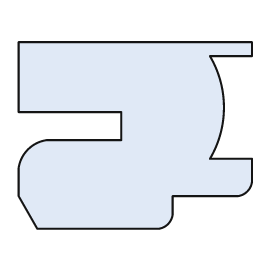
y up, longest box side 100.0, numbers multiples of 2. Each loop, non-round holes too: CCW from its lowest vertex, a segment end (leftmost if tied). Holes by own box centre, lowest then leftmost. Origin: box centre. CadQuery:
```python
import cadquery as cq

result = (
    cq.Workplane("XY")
    .moveTo(-42.0, -40.0)
    .lineTo(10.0, -40.0)
    .threePointArc((14.0, -38.0), (16.0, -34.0))
    .lineTo(16.0, -26.0)
    .lineTo(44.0, -26.0)
    .threePointArc((48.0, -24.0), (50.0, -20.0))
    .lineTo(50.0, -10.0)
    .lineTo(32.0, -10.0)
    .threePointArc((38.0, 12.0), (32.0, 34.0))
    .lineTo(50.0, 34.0)
    .lineTo(50.0, 40.0)
    .lineTo(-50.0, 40.0)
    .lineTo(-50.0, 10.0)
    .lineTo(-6.0, 10.0)
    .lineTo(-6.0, -2.0)
    .lineTo(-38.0, -2.0)
    .threePointArc((-46.0, -6.0), (-50.0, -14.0))
    .lineTo(-50.0, -26.0)
    .close()
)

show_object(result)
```